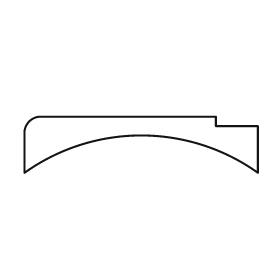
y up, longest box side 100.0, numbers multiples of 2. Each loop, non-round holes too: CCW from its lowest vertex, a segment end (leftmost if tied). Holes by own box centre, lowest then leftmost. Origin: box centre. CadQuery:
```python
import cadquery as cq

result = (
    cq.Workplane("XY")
    .moveTo(-50.0, -12.0)
    .threePointArc((0.0, 4.0), (50.0, -12.0))
    .lineTo(50.0, 8.0)
    .lineTo(32.0, 8.0)
    .lineTo(32.0, 12.0)
    .lineTo(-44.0, 12.0)
    .threePointArc((-48.0, 10.0), (-50.0, 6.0))
    .close()
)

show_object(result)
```